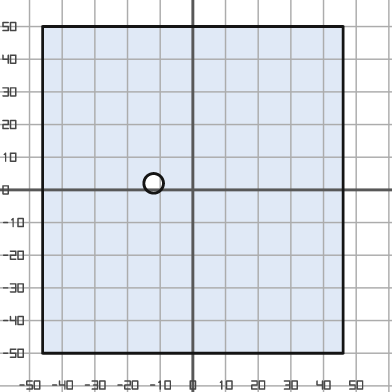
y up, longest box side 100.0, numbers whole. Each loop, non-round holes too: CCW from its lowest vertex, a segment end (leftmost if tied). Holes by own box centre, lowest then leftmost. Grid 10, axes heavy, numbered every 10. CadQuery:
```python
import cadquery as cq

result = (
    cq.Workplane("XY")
    .moveTo(-46.0, -50.0)
    .lineTo(46.0, -50.0)
    .lineTo(46.0, 50.0)
    .lineTo(-46.0, 50.0)
    .close()
    .moveTo(-12.0, 2.0)
    .circle(3.0)
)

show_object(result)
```